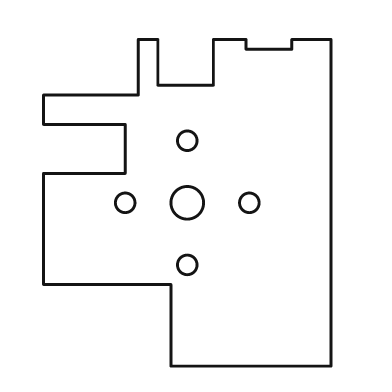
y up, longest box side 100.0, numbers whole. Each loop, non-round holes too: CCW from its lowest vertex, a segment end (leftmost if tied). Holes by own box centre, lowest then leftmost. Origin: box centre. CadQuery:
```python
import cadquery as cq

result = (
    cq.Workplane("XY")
    .moveTo(-5.0, -50.0)
    .lineTo(44.0, -50.0)
    .lineTo(44.0, 50.0)
    .lineTo(32.0, 50.0)
    .lineTo(32.0, 47.0)
    .lineTo(18.0, 47.0)
    .lineTo(18.0, 50.0)
    .lineTo(8.0, 50.0)
    .lineTo(8.0, 36.0)
    .lineTo(-9.0, 36.0)
    .lineTo(-9.0, 50.0)
    .lineTo(-15.0, 50.0)
    .lineTo(-15.0, 33.0)
    .lineTo(-44.0, 33.0)
    .lineTo(-44.0, 24.0)
    .lineTo(-19.0, 24.0)
    .lineTo(-19.0, 9.0)
    .lineTo(-44.0, 9.0)
    .lineTo(-44.0, -25.0)
    .lineTo(-5.0, -25.0)
    .close()
    .moveTo(0.0, -19.0)
    .circle(3.0)
    .moveTo(-19.0, 0.0)
    .circle(3.0)
    .moveTo(0.0, 0.0)
    .circle(5.0)
    .moveTo(19.0, 0.0)
    .circle(3.0)
    .moveTo(0.0, 19.0)
    .circle(3.0)
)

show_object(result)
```